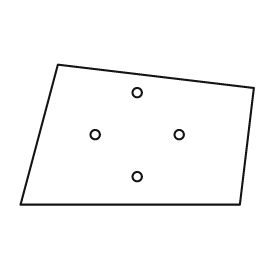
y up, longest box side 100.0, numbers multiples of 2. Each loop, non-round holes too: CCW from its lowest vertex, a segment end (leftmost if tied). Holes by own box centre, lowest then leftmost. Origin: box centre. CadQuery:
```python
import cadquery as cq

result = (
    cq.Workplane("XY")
    .moveTo(-50.0, -30.0)
    .lineTo(44.0, -30.0)
    .lineTo(50.0, 20.0)
    .lineTo(-34.0, 30.0)
    .close()
    .moveTo(0.0, -18.0)
    .circle(2.0)
    .moveTo(-18.0, 0.0)
    .circle(2.0)
    .moveTo(18.0, 0.0)
    .circle(2.0)
    .moveTo(0.0, 18.0)
    .circle(2.0)
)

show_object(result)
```